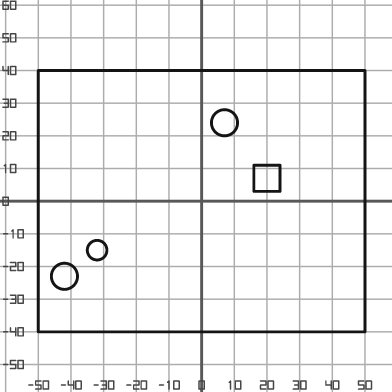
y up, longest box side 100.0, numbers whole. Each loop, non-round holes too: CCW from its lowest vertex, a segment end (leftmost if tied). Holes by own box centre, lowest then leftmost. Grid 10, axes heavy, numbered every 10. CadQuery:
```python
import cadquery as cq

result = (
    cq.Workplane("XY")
    .moveTo(-50.0, -40.0)
    .lineTo(50.0, -40.0)
    .lineTo(50.0, 40.0)
    .lineTo(-50.0, 40.0)
    .close()
    .moveTo(-42.0, -23.0)
    .circle(4.0)
    .moveTo(-32.0, -15.0)
    .circle(3.0)
    .moveTo(16.0, 3.0)
    .lineTo(24.0, 3.0)
    .lineTo(24.0, 11.0)
    .lineTo(16.0, 11.0)
    .close()
    .moveTo(7.0, 24.0)
    .circle(4.0)
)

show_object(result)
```